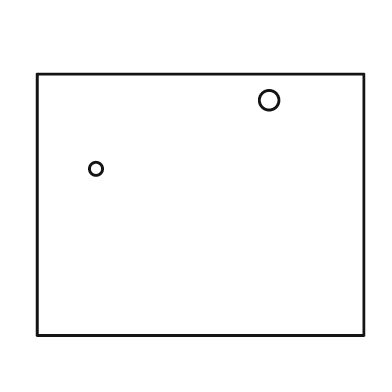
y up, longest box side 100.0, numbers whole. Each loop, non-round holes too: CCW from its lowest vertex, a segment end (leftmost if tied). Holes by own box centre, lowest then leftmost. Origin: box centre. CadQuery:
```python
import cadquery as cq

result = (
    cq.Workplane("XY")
    .moveTo(-50.0, -40.0)
    .lineTo(50.0, -40.0)
    .lineTo(50.0, 40.0)
    .lineTo(-50.0, 40.0)
    .close()
    .moveTo(-32.0, 11.0)
    .circle(2.0)
    .moveTo(21.0, 32.0)
    .circle(3.0)
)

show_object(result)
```